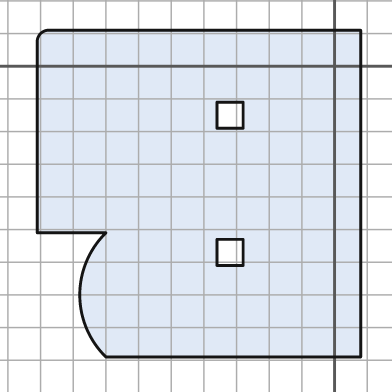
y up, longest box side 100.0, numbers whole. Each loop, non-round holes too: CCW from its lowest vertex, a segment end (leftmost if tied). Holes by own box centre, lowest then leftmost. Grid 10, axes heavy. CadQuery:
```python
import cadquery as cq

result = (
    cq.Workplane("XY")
    .moveTo(-70.0, -89.0)
    .lineTo(8.0, -89.0)
    .lineTo(8.0, 11.0)
    .lineTo(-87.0, 11.0)
    .threePointArc((-90.0, 10.0), (-91.0, 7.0))
    .lineTo(-91.0, -51.0)
    .lineTo(-70.0, -51.0)
    .threePointArc((-78.0, -70.0), (-70.0, -89.0))
    .close()
    .moveTo(-36.0, -61.0)
    .lineTo(-28.0, -61.0)
    .lineTo(-28.0, -53.0)
    .lineTo(-36.0, -53.0)
    .close()
    .moveTo(-36.0, -19.0)
    .lineTo(-28.0, -19.0)
    .lineTo(-28.0, -11.0)
    .lineTo(-36.0, -11.0)
    .close()
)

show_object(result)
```